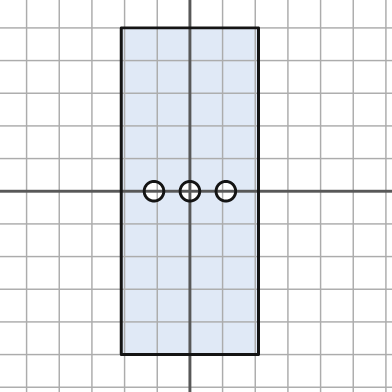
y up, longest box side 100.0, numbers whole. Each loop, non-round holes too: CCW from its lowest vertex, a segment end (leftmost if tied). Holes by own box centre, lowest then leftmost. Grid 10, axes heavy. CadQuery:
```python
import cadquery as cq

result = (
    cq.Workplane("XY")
    .moveTo(-21.0, -50.0)
    .lineTo(21.0, -50.0)
    .lineTo(21.0, 50.0)
    .lineTo(-21.0, 50.0)
    .close()
    .moveTo(-11.0, 0.0)
    .circle(3.0)
    .moveTo(0.0, 0.0)
    .circle(3.0)
    .moveTo(11.0, 0.0)
    .circle(3.0)
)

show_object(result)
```